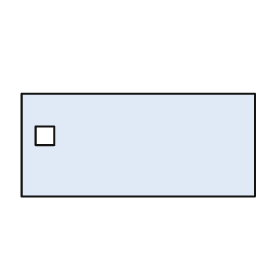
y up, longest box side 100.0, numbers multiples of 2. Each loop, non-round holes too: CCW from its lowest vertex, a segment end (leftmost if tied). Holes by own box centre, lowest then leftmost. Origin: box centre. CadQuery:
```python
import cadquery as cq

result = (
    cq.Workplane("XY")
    .moveTo(-50.0, -22.0)
    .lineTo(50.0, -22.0)
    .lineTo(50.0, 22.0)
    .lineTo(-50.0, 22.0)
    .close()
    .moveTo(-44.0, 0.0)
    .lineTo(-36.0, 0.0)
    .lineTo(-36.0, 8.0)
    .lineTo(-44.0, 8.0)
    .close()
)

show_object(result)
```